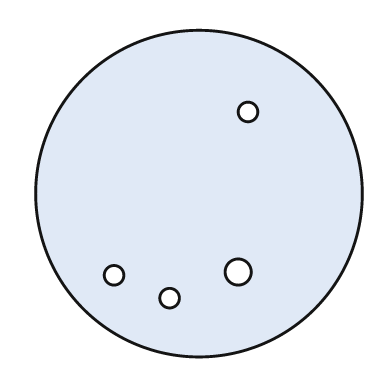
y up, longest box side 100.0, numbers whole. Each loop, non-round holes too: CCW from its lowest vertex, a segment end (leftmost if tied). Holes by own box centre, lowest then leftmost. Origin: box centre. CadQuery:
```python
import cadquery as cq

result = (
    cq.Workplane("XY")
    .moveTo(0.0, 0.0)
    .circle(50.0)
    .moveTo(-9.0, -32.0)
    .circle(3.0)
    .moveTo(-26.0, -25.0)
    .circle(3.0)
    .moveTo(12.0, -24.0)
    .circle(4.0)
    .moveTo(15.0, 25.0)
    .circle(3.0)
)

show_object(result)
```